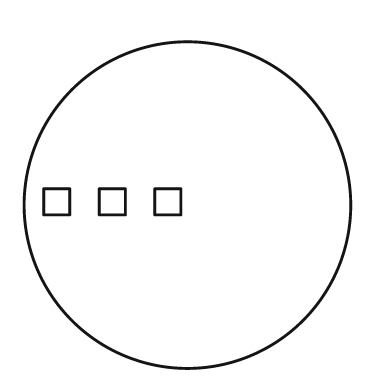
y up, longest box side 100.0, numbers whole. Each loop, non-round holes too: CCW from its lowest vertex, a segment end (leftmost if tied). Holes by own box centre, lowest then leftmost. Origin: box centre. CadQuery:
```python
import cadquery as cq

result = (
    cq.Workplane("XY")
    .moveTo(0.0, 0.0)
    .circle(50.0)
    .moveTo(-44.0, -3.0)
    .lineTo(-36.0, -3.0)
    .lineTo(-36.0, 5.0)
    .lineTo(-44.0, 5.0)
    .close()
    .moveTo(-27.0, -3.0)
    .lineTo(-19.0, -3.0)
    .lineTo(-19.0, 5.0)
    .lineTo(-27.0, 5.0)
    .close()
    .moveTo(-10.0, -3.0)
    .lineTo(-2.0, -3.0)
    .lineTo(-2.0, 5.0)
    .lineTo(-10.0, 5.0)
    .close()
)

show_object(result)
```